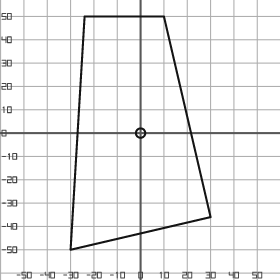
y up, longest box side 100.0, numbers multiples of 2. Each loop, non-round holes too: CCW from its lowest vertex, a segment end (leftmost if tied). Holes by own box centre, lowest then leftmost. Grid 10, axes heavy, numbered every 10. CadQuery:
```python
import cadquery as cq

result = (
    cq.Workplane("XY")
    .moveTo(-30.0, -50.0)
    .lineTo(30.0, -36.0)
    .lineTo(10.0, 50.0)
    .lineTo(-24.0, 50.0)
    .close()
    .moveTo(0.0, 0.0)
    .circle(2.0)
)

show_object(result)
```